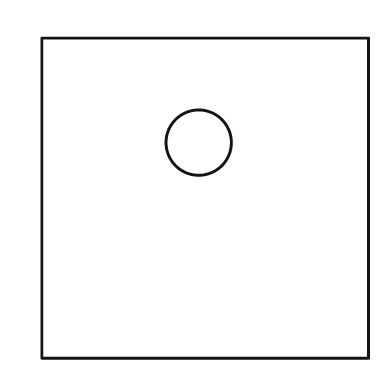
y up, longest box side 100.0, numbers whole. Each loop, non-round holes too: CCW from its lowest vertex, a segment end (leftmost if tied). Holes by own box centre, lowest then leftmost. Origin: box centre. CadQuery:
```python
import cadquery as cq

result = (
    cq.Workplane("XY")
    .moveTo(-50.0, -49.0)
    .lineTo(50.0, -49.0)
    .lineTo(50.0, 49.0)
    .lineTo(-50.0, 49.0)
    .close()
    .moveTo(-2.0, 17.0)
    .circle(10.0)
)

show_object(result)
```